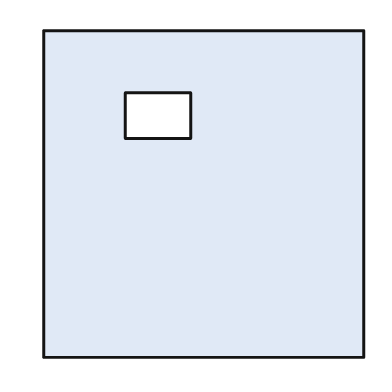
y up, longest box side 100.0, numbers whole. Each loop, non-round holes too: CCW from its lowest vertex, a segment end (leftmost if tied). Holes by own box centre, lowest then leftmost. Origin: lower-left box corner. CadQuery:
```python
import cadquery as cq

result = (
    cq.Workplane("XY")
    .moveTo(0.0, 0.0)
    .lineTo(98.0, 0.0)
    .lineTo(98.0, 100.0)
    .lineTo(0.0, 100.0)
    .close()
    .moveTo(25.0, 67.0)
    .lineTo(45.0, 67.0)
    .lineTo(45.0, 81.0)
    .lineTo(25.0, 81.0)
    .close()
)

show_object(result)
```